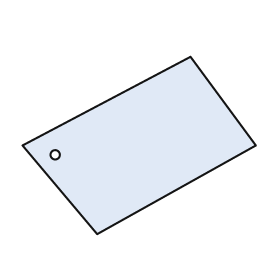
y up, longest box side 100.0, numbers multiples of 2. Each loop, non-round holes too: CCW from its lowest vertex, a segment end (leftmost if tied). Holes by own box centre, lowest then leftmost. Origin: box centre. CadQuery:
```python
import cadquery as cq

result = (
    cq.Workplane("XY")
    .moveTo(-18.0, -38.0)
    .lineTo(50.0, 0.0)
    .lineTo(22.0, 38.0)
    .lineTo(-50.0, 0.0)
    .close()
    .moveTo(-36.0, -4.0)
    .circle(2.0)
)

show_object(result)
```